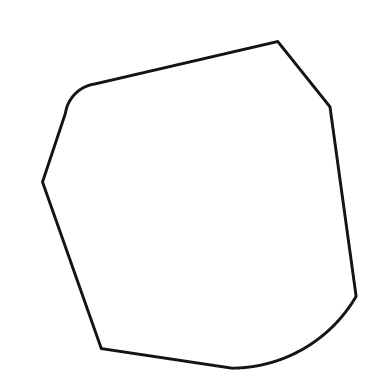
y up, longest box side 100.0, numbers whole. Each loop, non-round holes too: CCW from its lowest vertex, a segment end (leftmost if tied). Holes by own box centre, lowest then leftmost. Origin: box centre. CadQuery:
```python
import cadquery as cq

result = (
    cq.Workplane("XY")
    .moveTo(10.0, -50.0)
    .threePointArc((32.0, -44.0), (48.0, -28.0))
    .lineTo(40.0, 30.0)
    .lineTo(24.0, 50.0)
    .lineTo(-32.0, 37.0)
    .threePointArc((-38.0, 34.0), (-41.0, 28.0))
    .lineTo(-48.0, 7.0)
    .lineTo(-30.0, -44.0)
    .close()
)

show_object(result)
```